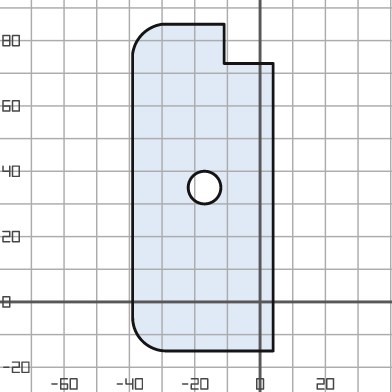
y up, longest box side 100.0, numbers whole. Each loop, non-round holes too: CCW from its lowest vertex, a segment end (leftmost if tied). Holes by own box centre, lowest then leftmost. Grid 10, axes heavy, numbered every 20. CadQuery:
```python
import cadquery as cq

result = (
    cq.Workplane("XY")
    .moveTo(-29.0, -15.0)
    .lineTo(4.0, -15.0)
    .lineTo(4.0, 73.0)
    .lineTo(-11.0, 73.0)
    .lineTo(-11.0, 85.0)
    .lineTo(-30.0, 85.0)
    .threePointArc((-36.0, 82.0), (-39.0, 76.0))
    .lineTo(-39.0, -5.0)
    .threePointArc((-36.0, -12.0), (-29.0, -15.0))
    .close()
    .moveTo(-17.0, 35.0)
    .circle(5.0)
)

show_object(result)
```